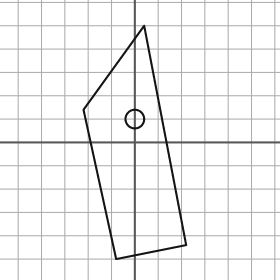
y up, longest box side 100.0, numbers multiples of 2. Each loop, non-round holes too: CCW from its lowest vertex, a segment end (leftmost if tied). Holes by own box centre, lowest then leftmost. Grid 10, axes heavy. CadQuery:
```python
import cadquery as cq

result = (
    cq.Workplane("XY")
    .moveTo(-8.0, -50.0)
    .lineTo(22.0, -44.0)
    .lineTo(4.0, 50.0)
    .lineTo(-22.0, 14.0)
    .close()
    .moveTo(0.0, 10.0)
    .circle(4.0)
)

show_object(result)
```